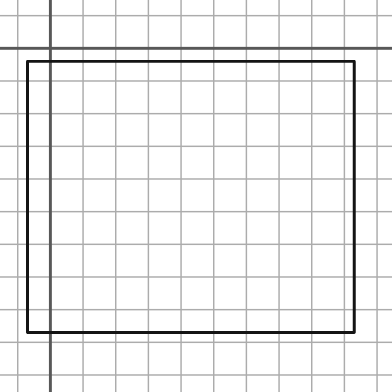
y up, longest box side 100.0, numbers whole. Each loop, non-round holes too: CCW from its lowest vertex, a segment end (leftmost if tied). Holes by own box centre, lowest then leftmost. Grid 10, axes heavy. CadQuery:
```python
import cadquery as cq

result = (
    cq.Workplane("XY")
    .moveTo(-7.0, -87.0)
    .lineTo(93.0, -87.0)
    .lineTo(93.0, -4.0)
    .lineTo(-7.0, -4.0)
    .close()
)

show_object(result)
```